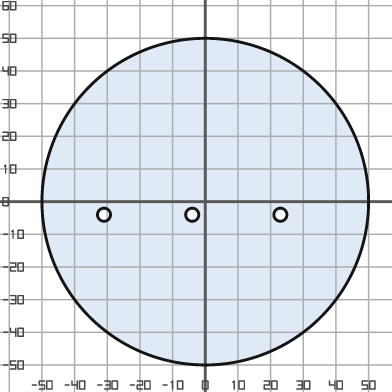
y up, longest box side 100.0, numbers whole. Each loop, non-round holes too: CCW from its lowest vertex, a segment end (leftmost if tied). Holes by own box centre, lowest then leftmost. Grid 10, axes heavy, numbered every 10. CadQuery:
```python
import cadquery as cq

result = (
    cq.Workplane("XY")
    .moveTo(0.0, 0.0)
    .circle(50.0)
    .moveTo(-31.0, -4.0)
    .circle(2.0)
    .moveTo(-4.0, -4.0)
    .circle(2.0)
    .moveTo(23.0, -4.0)
    .circle(2.0)
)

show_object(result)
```